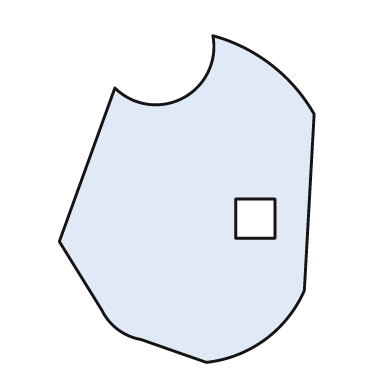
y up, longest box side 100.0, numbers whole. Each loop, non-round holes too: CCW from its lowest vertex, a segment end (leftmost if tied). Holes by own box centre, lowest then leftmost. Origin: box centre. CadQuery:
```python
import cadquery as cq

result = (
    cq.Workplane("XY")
    .moveTo(6.0, -50.0)
    .threePointArc((24.0, -43.0), (36.0, -28.0))
    .lineTo(39.0, 26.0)
    .threePointArc((26.0, 41.0), (8.0, 50.0))
    .threePointArc((-1.0, 31.0), (-22.0, 34.0))
    .lineTo(-39.0, -13.0)
    .lineTo(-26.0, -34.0)
    .threePointArc((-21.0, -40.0), (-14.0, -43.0))
    .close()
    .moveTo(15.0, -12.0)
    .lineTo(27.0, -12.0)
    .lineTo(27.0, 0.0)
    .lineTo(15.0, 0.0)
    .close()
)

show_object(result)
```